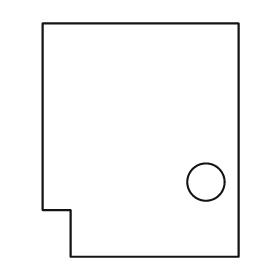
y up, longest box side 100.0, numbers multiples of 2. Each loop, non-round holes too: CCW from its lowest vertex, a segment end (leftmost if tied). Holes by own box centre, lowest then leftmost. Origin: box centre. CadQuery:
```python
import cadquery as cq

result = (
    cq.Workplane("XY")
    .moveTo(-30.0, -50.0)
    .lineTo(42.0, -50.0)
    .lineTo(42.0, 50.0)
    .lineTo(-42.0, 50.0)
    .lineTo(-42.0, -30.0)
    .lineTo(-30.0, -30.0)
    .close()
    .moveTo(28.0, -18.0)
    .circle(8.0)
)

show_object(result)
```